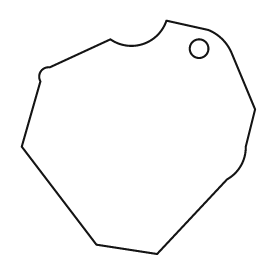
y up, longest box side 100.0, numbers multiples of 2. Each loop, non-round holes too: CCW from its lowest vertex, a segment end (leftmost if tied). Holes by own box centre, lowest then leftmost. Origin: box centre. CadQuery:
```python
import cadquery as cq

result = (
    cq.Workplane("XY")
    .moveTo(8.0, -50.0)
    .lineTo(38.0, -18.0)
    .threePointArc((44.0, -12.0), (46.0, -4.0))
    .lineTo(50.0, 12.0)
    .lineTo(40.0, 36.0)
    .threePointArc((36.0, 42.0), (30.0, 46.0))
    .lineTo(12.0, 50.0)
    .threePointArc((2.0, 40.0), (-12.0, 42.0))
    .lineTo(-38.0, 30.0)
    .threePointArc((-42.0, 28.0), (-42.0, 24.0))
    .lineTo(-50.0, -4.0)
    .lineTo(-18.0, -46.0)
    .close()
    .moveTo(26.0, 38.0)
    .circle(4.0)
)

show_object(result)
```